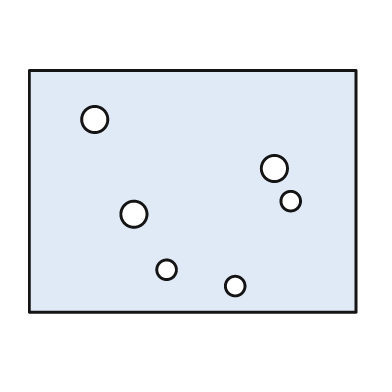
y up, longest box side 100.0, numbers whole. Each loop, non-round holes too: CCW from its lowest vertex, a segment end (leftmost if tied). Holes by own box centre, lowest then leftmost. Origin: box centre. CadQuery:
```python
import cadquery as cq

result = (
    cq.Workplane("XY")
    .moveTo(-50.0, -37.0)
    .lineTo(50.0, -37.0)
    .lineTo(50.0, 37.0)
    .lineTo(-50.0, 37.0)
    .close()
    .moveTo(13.0, -29.0)
    .circle(3.0)
    .moveTo(-8.0, -24.0)
    .circle(3.0)
    .moveTo(-18.0, -7.0)
    .circle(4.0)
    .moveTo(30.0, -3.0)
    .circle(3.0)
    .moveTo(25.0, 7.0)
    .circle(4.0)
    .moveTo(-30.0, 22.0)
    .circle(4.0)
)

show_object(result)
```